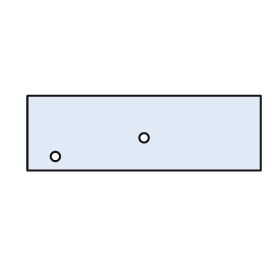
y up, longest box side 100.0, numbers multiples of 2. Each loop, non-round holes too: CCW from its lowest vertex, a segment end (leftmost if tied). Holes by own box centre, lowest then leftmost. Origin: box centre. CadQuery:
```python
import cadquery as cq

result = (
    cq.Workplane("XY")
    .moveTo(-50.0, -16.0)
    .lineTo(50.0, -16.0)
    .lineTo(50.0, 16.0)
    .lineTo(-50.0, 16.0)
    .close()
    .moveTo(-38.0, -10.0)
    .circle(2.0)
    .moveTo(0.0, -2.0)
    .circle(2.0)
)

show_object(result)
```